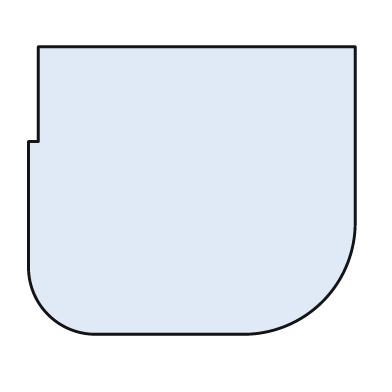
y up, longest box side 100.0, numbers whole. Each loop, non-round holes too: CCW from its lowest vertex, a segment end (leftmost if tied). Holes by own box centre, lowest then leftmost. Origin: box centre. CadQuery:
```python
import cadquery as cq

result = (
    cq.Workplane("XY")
    .moveTo(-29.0, -44.0)
    .lineTo(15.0, -44.0)
    .threePointArc((40.0, -34.0), (50.0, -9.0))
    .lineTo(50.0, 44.0)
    .lineTo(-47.0, 44.0)
    .lineTo(-47.0, 15.0)
    .lineTo(-50.0, 15.0)
    .lineTo(-50.0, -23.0)
    .threePointArc((-44.0, -38.0), (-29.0, -44.0))
    .close()
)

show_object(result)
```